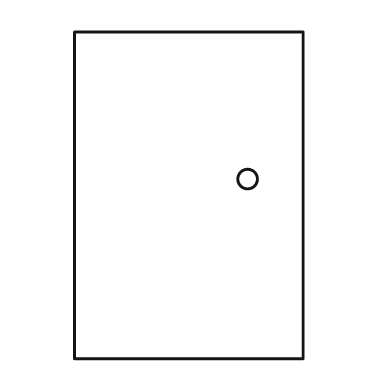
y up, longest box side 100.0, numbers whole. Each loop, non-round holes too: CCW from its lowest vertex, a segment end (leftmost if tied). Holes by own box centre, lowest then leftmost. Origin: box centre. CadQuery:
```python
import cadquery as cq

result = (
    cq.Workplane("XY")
    .moveTo(-35.0, -50.0)
    .lineTo(35.0, -50.0)
    .lineTo(35.0, 50.0)
    .lineTo(-35.0, 50.0)
    .close()
    .moveTo(18.0, 5.0)
    .circle(3.0)
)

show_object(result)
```